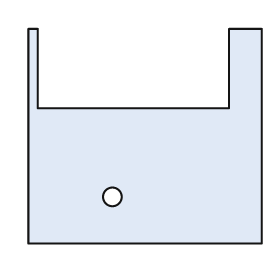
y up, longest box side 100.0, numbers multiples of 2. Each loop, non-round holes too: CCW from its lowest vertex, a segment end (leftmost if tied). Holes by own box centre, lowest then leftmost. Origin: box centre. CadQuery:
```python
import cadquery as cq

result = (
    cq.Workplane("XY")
    .moveTo(-50.0, -46.0)
    .lineTo(50.0, -46.0)
    .lineTo(50.0, 46.0)
    .lineTo(36.0, 46.0)
    .lineTo(36.0, 12.0)
    .lineTo(-46.0, 12.0)
    .lineTo(-46.0, 46.0)
    .lineTo(-50.0, 46.0)
    .close()
    .moveTo(-14.0, -26.0)
    .circle(4.0)
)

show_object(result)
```